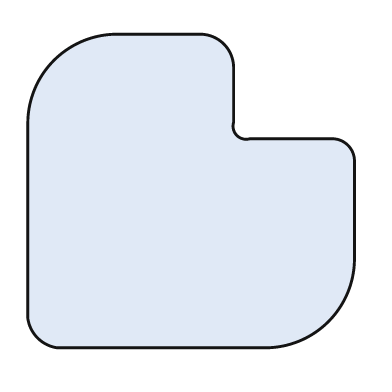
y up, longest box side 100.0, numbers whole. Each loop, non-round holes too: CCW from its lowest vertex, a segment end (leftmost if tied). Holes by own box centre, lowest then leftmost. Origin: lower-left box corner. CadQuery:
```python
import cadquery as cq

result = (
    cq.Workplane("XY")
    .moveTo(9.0, 0.0)
    .lineTo(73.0, 0.0)
    .threePointArc((92.0, 8.0), (100.0, 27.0))
    .lineTo(100.0, 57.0)
    .threePointArc((98.0, 62.0), (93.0, 64.0))
    .lineTo(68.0, 64.0)
    .threePointArc((64.0, 65.0), (63.0, 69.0))
    .lineTo(63.0, 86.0)
    .threePointArc((60.0, 93.0), (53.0, 96.0))
    .lineTo(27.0, 96.0)
    .threePointArc((8.0, 88.0), (0.0, 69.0))
    .lineTo(0.0, 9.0)
    .threePointArc((3.0, 3.0), (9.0, 0.0))
    .close()
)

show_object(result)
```